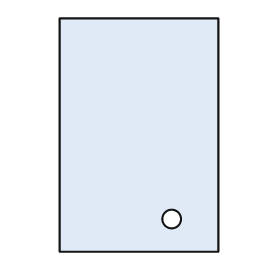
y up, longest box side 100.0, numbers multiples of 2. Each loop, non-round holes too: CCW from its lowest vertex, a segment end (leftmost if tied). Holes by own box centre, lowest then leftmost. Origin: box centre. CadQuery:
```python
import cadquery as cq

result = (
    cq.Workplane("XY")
    .moveTo(-34.0, -50.0)
    .lineTo(34.0, -50.0)
    .lineTo(34.0, 50.0)
    .lineTo(-34.0, 50.0)
    .close()
    .moveTo(14.0, -36.0)
    .circle(4.0)
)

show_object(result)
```